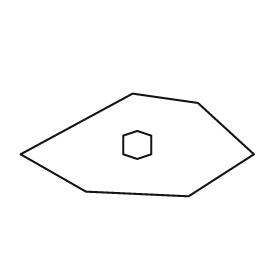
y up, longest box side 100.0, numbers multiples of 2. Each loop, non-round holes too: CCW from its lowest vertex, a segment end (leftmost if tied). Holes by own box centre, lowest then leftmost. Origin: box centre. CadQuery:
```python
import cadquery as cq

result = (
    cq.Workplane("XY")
    .moveTo(22.0, -22.0)
    .lineTo(50.0, -4.0)
    .lineTo(26.0, 18.0)
    .lineTo(-2.0, 22.0)
    .lineTo(-50.0, -4.0)
    .lineTo(-22.0, -20.0)
    .close()
    .moveTo(0.0, -6.0)
    .lineTo(6.0, -4.0)
    .lineTo(6.0, 4.0)
    .lineTo(0.0, 6.0)
    .lineTo(-6.0, 4.0)
    .lineTo(-6.0, -4.0)
    .close()
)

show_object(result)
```